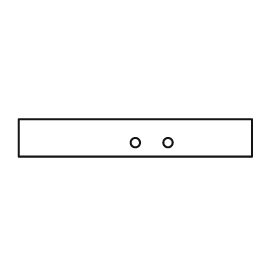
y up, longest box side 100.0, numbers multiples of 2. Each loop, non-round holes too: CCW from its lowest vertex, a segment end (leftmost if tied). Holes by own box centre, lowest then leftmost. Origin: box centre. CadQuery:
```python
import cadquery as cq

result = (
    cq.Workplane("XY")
    .moveTo(-50.0, -8.0)
    .lineTo(50.0, -8.0)
    .lineTo(50.0, 8.0)
    .lineTo(-50.0, 8.0)
    .close()
    .moveTo(0.0, -2.0)
    .circle(2.0)
    .moveTo(14.0, -2.0)
    .circle(2.0)
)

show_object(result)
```